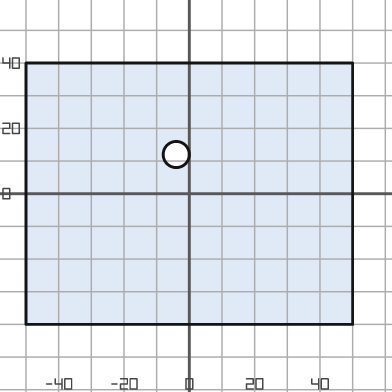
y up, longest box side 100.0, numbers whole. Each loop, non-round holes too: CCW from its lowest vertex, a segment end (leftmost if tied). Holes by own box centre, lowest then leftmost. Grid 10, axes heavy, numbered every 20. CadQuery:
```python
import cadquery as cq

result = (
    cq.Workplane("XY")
    .moveTo(-50.0, -40.0)
    .lineTo(50.0, -40.0)
    .lineTo(50.0, 40.0)
    .lineTo(-50.0, 40.0)
    .close()
    .moveTo(-4.0, 12.0)
    .circle(4.0)
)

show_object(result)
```